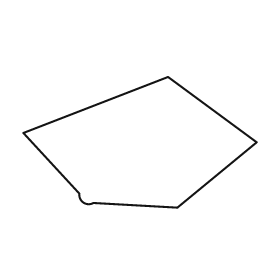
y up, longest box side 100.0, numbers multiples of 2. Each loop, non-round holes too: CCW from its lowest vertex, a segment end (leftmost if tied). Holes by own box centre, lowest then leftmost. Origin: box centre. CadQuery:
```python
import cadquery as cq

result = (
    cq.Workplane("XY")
    .moveTo(16.0, -28.0)
    .lineTo(50.0, 0.0)
    .lineTo(12.0, 28.0)
    .lineTo(-50.0, 4.0)
    .lineTo(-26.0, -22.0)
    .threePointArc((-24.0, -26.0), (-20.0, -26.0))
    .close()
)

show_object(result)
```